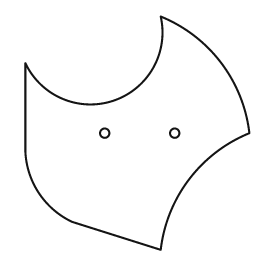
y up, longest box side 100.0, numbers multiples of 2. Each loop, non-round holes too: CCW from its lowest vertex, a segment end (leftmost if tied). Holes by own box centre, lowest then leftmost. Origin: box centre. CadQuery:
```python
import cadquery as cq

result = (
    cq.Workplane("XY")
    .moveTo(10.0, -50.0)
    .threePointArc((22.0, -20.0), (48.0, 0.0))
    .threePointArc((36.0, 30.0), (10.0, 50.0))
    .threePointArc((-10.0, 14.0), (-48.0, 30.0))
    .lineTo(-48.0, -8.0)
    .threePointArc((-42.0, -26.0), (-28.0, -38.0))
    .close()
    .moveTo(-14.0, 0.0)
    .circle(2.0)
    .moveTo(16.0, 0.0)
    .circle(2.0)
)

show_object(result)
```